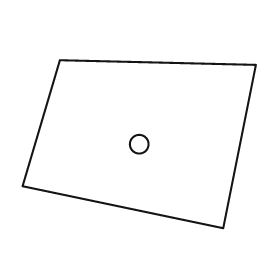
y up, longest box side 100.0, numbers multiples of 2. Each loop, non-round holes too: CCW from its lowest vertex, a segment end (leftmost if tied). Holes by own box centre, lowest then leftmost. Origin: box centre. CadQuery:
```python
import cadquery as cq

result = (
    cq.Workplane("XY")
    .moveTo(36.0, -36.0)
    .lineTo(50.0, 34.0)
    .lineTo(-34.0, 36.0)
    .lineTo(-50.0, -18.0)
    .close()
    .moveTo(0.0, 0.0)
    .circle(4.0)
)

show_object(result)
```